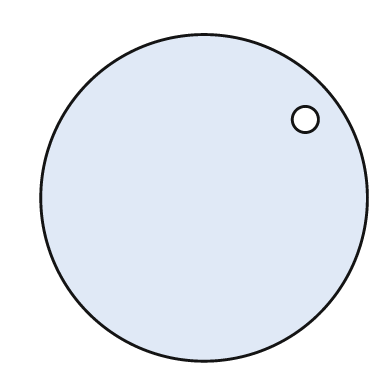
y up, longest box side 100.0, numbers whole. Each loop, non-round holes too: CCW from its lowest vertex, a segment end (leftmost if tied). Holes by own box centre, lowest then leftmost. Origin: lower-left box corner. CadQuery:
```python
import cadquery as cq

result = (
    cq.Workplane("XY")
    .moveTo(50.0, 50.0)
    .circle(50.0)
    .moveTo(81.0, 74.0)
    .circle(4.0)
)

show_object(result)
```